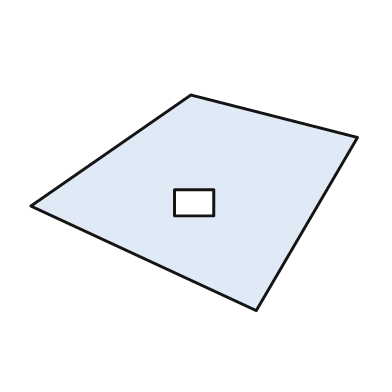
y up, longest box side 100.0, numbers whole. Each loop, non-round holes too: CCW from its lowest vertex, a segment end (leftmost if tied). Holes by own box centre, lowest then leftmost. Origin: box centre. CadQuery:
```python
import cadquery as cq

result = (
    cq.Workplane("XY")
    .moveTo(19.0, -33.0)
    .lineTo(50.0, 20.0)
    .lineTo(-1.0, 33.0)
    .lineTo(-50.0, -1.0)
    .close()
    .moveTo(-6.0, -4.0)
    .lineTo(6.0, -4.0)
    .lineTo(6.0, 4.0)
    .lineTo(-6.0, 4.0)
    .close()
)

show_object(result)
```